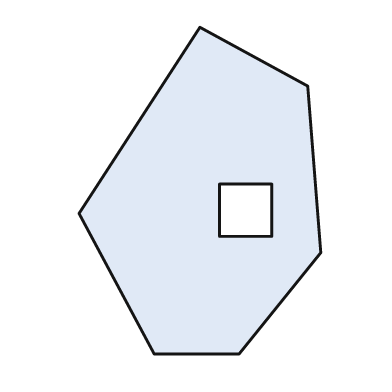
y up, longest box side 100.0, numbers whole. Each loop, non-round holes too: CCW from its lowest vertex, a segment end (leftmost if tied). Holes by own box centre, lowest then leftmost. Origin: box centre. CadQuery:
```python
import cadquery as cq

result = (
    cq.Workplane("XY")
    .moveTo(-14.0, -50.0)
    .lineTo(12.0, -50.0)
    .lineTo(37.0, -19.0)
    .lineTo(33.0, 32.0)
    .lineTo(0.0, 50.0)
    .lineTo(-37.0, -7.0)
    .close()
    .moveTo(6.0, -14.0)
    .lineTo(22.0, -14.0)
    .lineTo(22.0, 2.0)
    .lineTo(6.0, 2.0)
    .close()
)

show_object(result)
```